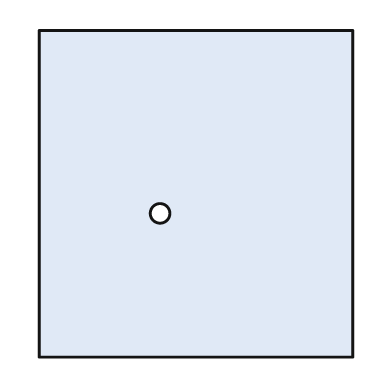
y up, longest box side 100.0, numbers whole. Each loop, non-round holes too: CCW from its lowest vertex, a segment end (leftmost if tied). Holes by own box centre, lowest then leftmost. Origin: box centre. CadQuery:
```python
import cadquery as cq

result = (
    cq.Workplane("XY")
    .moveTo(-48.0, -50.0)
    .lineTo(48.0, -50.0)
    .lineTo(48.0, 50.0)
    .lineTo(-48.0, 50.0)
    .close()
    .moveTo(-11.0, -6.0)
    .circle(3.0)
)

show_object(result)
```